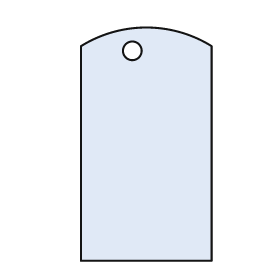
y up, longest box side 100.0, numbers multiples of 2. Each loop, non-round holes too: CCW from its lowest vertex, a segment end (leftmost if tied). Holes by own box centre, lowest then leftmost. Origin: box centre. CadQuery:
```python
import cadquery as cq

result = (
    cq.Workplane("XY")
    .moveTo(-28.0, -50.0)
    .lineTo(28.0, -50.0)
    .lineTo(28.0, 42.0)
    .threePointArc((0.0, 50.0), (-28.0, 42.0))
    .close()
    .moveTo(-6.0, 40.0)
    .circle(4.0)
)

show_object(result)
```